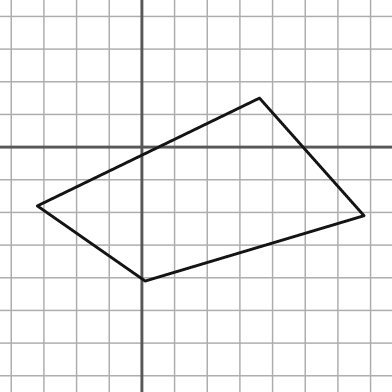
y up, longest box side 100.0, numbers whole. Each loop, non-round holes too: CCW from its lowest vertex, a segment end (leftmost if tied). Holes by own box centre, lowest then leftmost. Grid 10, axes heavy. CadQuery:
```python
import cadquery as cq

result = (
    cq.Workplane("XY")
    .moveTo(1.0, -41.0)
    .lineTo(68.0, -21.0)
    .lineTo(36.0, 15.0)
    .lineTo(-32.0, -18.0)
    .close()
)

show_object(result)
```